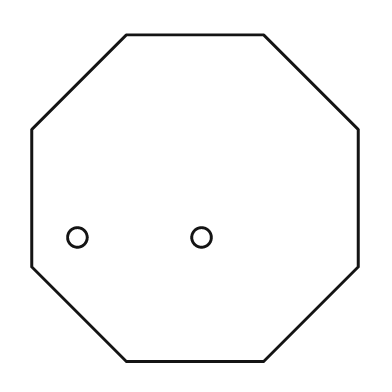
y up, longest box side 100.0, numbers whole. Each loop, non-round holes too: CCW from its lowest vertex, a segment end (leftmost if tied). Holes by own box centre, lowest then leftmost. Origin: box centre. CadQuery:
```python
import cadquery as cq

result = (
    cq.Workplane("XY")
    .moveTo(-21.0, -50.0)
    .lineTo(21.0, -50.0)
    .lineTo(50.0, -21.0)
    .lineTo(50.0, 21.0)
    .lineTo(21.0, 50.0)
    .lineTo(-21.0, 50.0)
    .lineTo(-50.0, 21.0)
    .lineTo(-50.0, -21.0)
    .close()
    .moveTo(-36.0, -12.0)
    .circle(3.0)
    .moveTo(2.0, -12.0)
    .circle(3.0)
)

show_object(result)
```